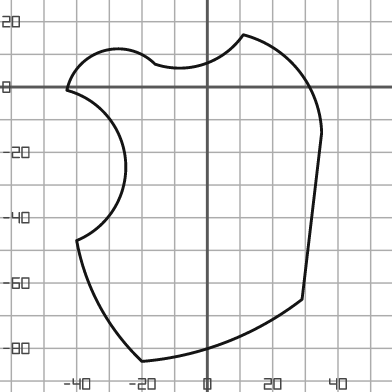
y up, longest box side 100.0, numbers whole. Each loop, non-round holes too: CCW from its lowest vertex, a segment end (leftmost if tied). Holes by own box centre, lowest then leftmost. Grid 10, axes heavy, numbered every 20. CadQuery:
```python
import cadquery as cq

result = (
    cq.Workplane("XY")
    .moveTo(-20.0, -84.0)
    .threePointArc((6.0, -78.0), (29.0, -65.0))
    .lineTo(35.0, -14.0)
    .threePointArc((28.0, 5.0), (11.0, 16.0))
    .threePointArc((-1.0, 7.0), (-16.0, 7.0))
    .threePointArc((-32.0, 11.0), (-43.0, -1.0))
    .threePointArc((-25.0, -23.0), (-40.0, -47.0))
    .threePointArc((-33.0, -67.0), (-20.0, -84.0))
    .close()
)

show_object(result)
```